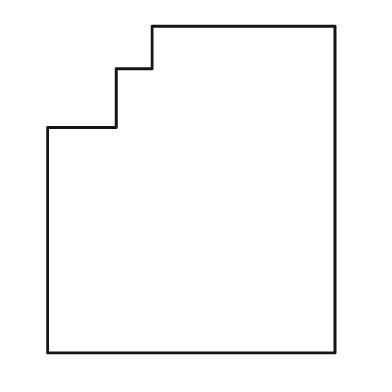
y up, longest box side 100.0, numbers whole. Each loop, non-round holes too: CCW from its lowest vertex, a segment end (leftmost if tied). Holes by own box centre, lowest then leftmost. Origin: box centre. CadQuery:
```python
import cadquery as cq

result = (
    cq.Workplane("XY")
    .moveTo(-44.0, -50.0)
    .lineTo(44.0, -50.0)
    .lineTo(44.0, 50.0)
    .lineTo(-12.0, 50.0)
    .lineTo(-12.0, 37.0)
    .lineTo(-23.0, 37.0)
    .lineTo(-23.0, 19.0)
    .lineTo(-44.0, 19.0)
    .close()
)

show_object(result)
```